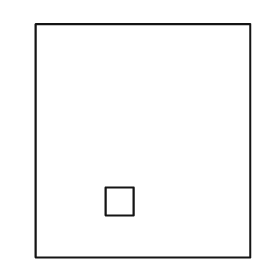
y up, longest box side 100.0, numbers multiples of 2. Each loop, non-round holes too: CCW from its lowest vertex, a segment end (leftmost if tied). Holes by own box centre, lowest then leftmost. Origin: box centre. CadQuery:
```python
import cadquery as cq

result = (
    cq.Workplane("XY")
    .moveTo(-46.0, -50.0)
    .lineTo(46.0, -50.0)
    .lineTo(46.0, 50.0)
    .lineTo(-46.0, 50.0)
    .close()
    .moveTo(-16.0, -32.0)
    .lineTo(-4.0, -32.0)
    .lineTo(-4.0, -20.0)
    .lineTo(-16.0, -20.0)
    .close()
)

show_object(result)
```